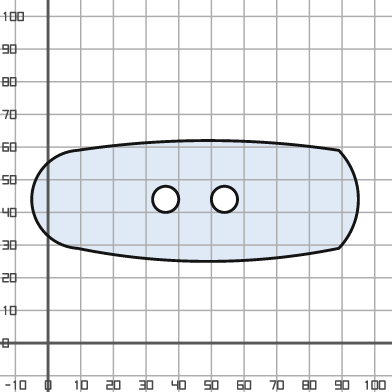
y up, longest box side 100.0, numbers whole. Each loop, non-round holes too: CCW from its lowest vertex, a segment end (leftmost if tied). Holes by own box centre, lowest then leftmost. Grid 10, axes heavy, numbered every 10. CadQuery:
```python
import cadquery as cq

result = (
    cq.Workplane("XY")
    .moveTo(9.0, 29.0)
    .threePointArc((49.0, 25.0), (89.0, 29.0))
    .threePointArc((95.0, 44.0), (89.0, 59.0))
    .threePointArc((49.0, 62.0), (9.0, 59.0))
    .threePointArc((-5.0, 44.0), (9.0, 29.0))
    .close()
    .moveTo(36.0, 44.0)
    .circle(4.0)
    .moveTo(54.0, 44.0)
    .circle(4.0)
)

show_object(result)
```